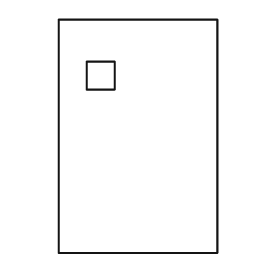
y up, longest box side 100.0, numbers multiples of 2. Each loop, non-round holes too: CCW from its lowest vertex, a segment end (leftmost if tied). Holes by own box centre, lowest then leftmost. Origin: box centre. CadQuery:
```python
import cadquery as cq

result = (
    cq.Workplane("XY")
    .moveTo(-34.0, -50.0)
    .lineTo(34.0, -50.0)
    .lineTo(34.0, 50.0)
    .lineTo(-34.0, 50.0)
    .close()
    .moveTo(-22.0, 20.0)
    .lineTo(-10.0, 20.0)
    .lineTo(-10.0, 32.0)
    .lineTo(-22.0, 32.0)
    .close()
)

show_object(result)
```